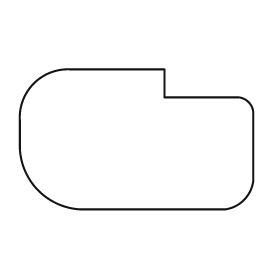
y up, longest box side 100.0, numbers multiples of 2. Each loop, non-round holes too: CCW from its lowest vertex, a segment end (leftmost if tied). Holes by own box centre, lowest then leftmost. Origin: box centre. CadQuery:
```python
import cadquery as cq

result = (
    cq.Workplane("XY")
    .moveTo(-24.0, -30.0)
    .lineTo(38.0, -30.0)
    .threePointArc((46.0, -26.0), (50.0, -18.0))
    .lineTo(50.0, 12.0)
    .threePointArc((48.0, 16.0), (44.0, 18.0))
    .lineTo(12.0, 18.0)
    .lineTo(12.0, 30.0)
    .lineTo(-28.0, 30.0)
    .threePointArc((-44.0, 24.0), (-50.0, 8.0))
    .lineTo(-50.0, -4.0)
    .threePointArc((-42.0, -22.0), (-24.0, -30.0))
    .close()
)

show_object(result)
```